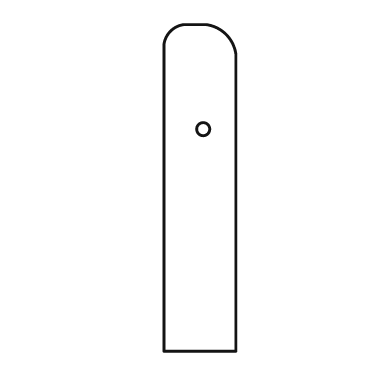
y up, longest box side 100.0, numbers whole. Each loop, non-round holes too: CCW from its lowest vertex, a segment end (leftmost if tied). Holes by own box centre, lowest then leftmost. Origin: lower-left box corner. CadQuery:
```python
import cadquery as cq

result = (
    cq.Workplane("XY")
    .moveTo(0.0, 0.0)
    .lineTo(22.0, 0.0)
    .lineTo(22.0, 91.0)
    .threePointArc((19.0, 97.0), (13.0, 100.0))
    .lineTo(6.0, 100.0)
    .threePointArc((2.0, 98.0), (0.0, 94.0))
    .close()
    .moveTo(12.0, 68.0)
    .circle(2.0)
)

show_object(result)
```